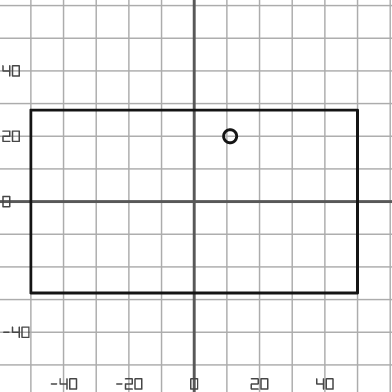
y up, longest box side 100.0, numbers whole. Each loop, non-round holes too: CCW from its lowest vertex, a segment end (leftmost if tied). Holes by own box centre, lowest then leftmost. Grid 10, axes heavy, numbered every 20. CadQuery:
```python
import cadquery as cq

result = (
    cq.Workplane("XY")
    .moveTo(-50.0, -28.0)
    .lineTo(50.0, -28.0)
    .lineTo(50.0, 28.0)
    .lineTo(-50.0, 28.0)
    .close()
    .moveTo(11.0, 20.0)
    .circle(2.0)
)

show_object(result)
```